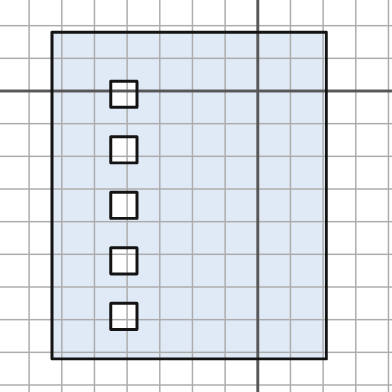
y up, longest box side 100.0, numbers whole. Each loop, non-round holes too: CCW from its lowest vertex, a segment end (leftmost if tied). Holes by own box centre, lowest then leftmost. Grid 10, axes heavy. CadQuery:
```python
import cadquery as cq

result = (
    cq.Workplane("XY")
    .moveTo(-63.0, -82.0)
    .lineTo(21.0, -82.0)
    .lineTo(21.0, 18.0)
    .lineTo(-63.0, 18.0)
    .close()
    .moveTo(-45.0, -73.0)
    .lineTo(-37.0, -73.0)
    .lineTo(-37.0, -65.0)
    .lineTo(-45.0, -65.0)
    .close()
    .moveTo(-45.0, -56.0)
    .lineTo(-37.0, -56.0)
    .lineTo(-37.0, -48.0)
    .lineTo(-45.0, -48.0)
    .close()
    .moveTo(-45.0, -39.0)
    .lineTo(-37.0, -39.0)
    .lineTo(-37.0, -31.0)
    .lineTo(-45.0, -31.0)
    .close()
    .moveTo(-45.0, -22.0)
    .lineTo(-37.0, -22.0)
    .lineTo(-37.0, -14.0)
    .lineTo(-45.0, -14.0)
    .close()
    .moveTo(-45.0, -5.0)
    .lineTo(-37.0, -5.0)
    .lineTo(-37.0, 3.0)
    .lineTo(-45.0, 3.0)
    .close()
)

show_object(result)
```